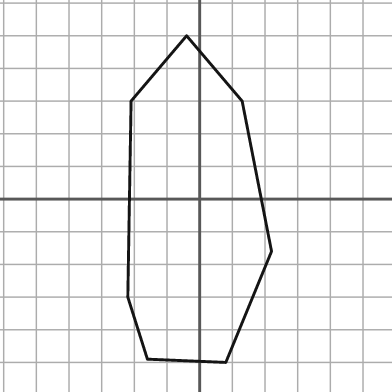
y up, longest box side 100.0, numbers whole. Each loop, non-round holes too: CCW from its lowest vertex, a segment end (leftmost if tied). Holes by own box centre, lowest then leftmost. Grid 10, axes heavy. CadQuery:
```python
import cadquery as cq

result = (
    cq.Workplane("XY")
    .moveTo(8.0, -50.0)
    .lineTo(22.0, -16.0)
    .lineTo(13.0, 30.0)
    .lineTo(-4.0, 50.0)
    .lineTo(-21.0, 30.0)
    .lineTo(-22.0, -30.0)
    .lineTo(-16.0, -49.0)
    .close()
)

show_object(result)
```